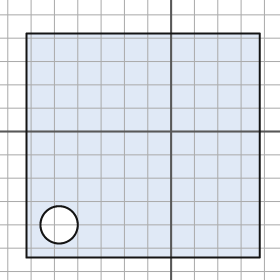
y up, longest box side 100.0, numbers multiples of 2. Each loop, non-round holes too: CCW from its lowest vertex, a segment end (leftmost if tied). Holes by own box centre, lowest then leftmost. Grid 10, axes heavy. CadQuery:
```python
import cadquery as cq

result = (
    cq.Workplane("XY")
    .moveTo(-62.0, -54.0)
    .lineTo(38.0, -54.0)
    .lineTo(38.0, 42.0)
    .lineTo(-62.0, 42.0)
    .close()
    .moveTo(-48.0, -40.0)
    .circle(8.0)
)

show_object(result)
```